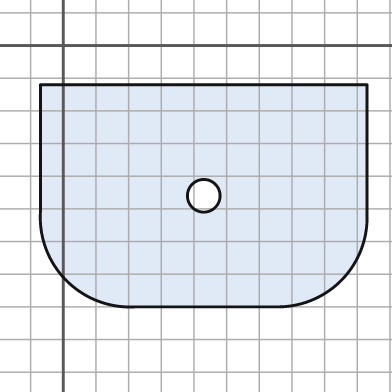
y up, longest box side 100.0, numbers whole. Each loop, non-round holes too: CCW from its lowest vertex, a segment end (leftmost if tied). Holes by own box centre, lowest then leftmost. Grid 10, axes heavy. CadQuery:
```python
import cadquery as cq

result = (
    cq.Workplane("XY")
    .moveTo(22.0, -80.0)
    .lineTo(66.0, -80.0)
    .threePointArc((85.0, -72.0), (93.0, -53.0))
    .lineTo(93.0, -12.0)
    .lineTo(-7.0, -12.0)
    .lineTo(-7.0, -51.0)
    .threePointArc((1.0, -72.0), (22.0, -80.0))
    .close()
    .moveTo(43.0, -46.0)
    .circle(5.0)
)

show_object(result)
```